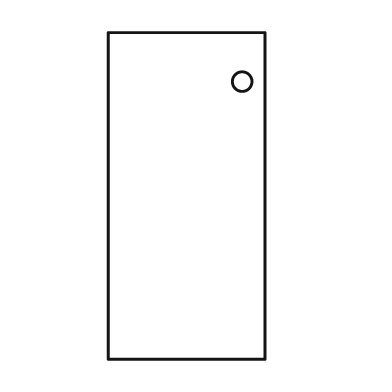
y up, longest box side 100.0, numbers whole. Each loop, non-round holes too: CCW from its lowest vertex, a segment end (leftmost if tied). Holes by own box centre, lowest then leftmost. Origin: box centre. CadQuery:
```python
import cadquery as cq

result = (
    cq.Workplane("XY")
    .moveTo(-24.0, -50.0)
    .lineTo(24.0, -50.0)
    .lineTo(24.0, 50.0)
    .lineTo(-24.0, 50.0)
    .close()
    .moveTo(17.0, 35.0)
    .circle(3.0)
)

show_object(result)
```